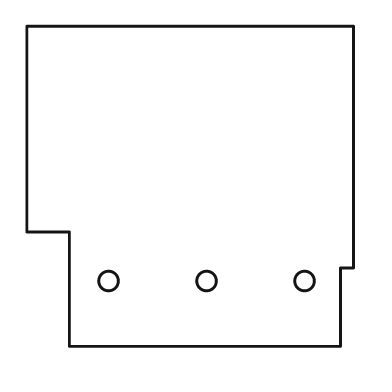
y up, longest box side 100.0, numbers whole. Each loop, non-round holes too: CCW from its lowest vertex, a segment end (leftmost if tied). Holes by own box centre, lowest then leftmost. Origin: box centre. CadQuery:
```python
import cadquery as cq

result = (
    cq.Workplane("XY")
    .moveTo(-37.0, -49.0)
    .lineTo(46.0, -49.0)
    .lineTo(46.0, -25.0)
    .lineTo(50.0, -25.0)
    .lineTo(50.0, 49.0)
    .lineTo(-50.0, 49.0)
    .lineTo(-50.0, -14.0)
    .lineTo(-37.0, -14.0)
    .close()
    .moveTo(-25.0, -29.0)
    .circle(3.0)
    .moveTo(5.0, -29.0)
    .circle(3.0)
    .moveTo(35.0, -29.0)
    .circle(3.0)
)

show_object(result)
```